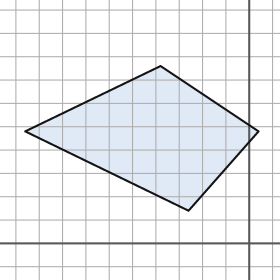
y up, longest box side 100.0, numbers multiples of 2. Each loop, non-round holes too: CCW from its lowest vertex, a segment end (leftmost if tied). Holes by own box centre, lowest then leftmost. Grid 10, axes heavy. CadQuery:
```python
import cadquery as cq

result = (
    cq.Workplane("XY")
    .moveTo(-26.0, 14.0)
    .lineTo(4.0, 48.0)
    .lineTo(-38.0, 76.0)
    .lineTo(-96.0, 48.0)
    .close()
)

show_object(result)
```